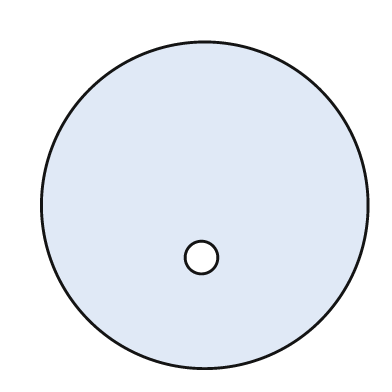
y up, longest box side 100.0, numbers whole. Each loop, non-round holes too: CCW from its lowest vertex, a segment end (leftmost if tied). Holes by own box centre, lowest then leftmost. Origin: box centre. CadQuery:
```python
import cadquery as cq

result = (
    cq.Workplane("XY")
    .moveTo(0.0, 0.0)
    .circle(50.0)
    .moveTo(-1.0, -16.0)
    .circle(5.0)
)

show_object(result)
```